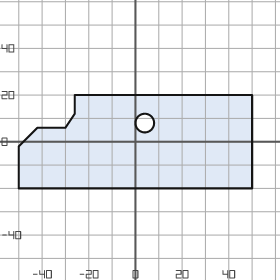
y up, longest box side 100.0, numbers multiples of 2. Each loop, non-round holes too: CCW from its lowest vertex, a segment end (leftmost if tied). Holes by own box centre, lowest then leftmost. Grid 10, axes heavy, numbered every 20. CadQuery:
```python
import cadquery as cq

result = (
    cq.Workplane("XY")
    .moveTo(-50.0, -20.0)
    .lineTo(50.0, -20.0)
    .lineTo(50.0, 20.0)
    .lineTo(-26.0, 20.0)
    .lineTo(-26.0, 12.0)
    .lineTo(-30.0, 6.0)
    .lineTo(-42.0, 6.0)
    .lineTo(-50.0, -2.0)
    .close()
    .moveTo(4.0, 8.0)
    .circle(4.0)
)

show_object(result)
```